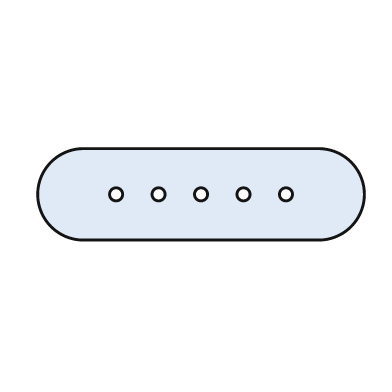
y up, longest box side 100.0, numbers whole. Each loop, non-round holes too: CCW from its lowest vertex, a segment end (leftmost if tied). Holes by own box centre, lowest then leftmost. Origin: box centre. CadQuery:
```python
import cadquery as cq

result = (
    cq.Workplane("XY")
    .moveTo(-36.0, -14.0)
    .lineTo(36.0, -14.0)
    .threePointArc((50.0, 0.0), (36.0, 14.0))
    .lineTo(-36.0, 14.0)
    .threePointArc((-50.0, 0.0), (-36.0, -14.0))
    .close()
    .moveTo(-26.0, 0.0)
    .circle(2.0)
    .moveTo(-13.0, 0.0)
    .circle(2.0)
    .moveTo(0.0, 0.0)
    .circle(2.0)
    .moveTo(13.0, 0.0)
    .circle(2.0)
    .moveTo(26.0, 0.0)
    .circle(2.0)
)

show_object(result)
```